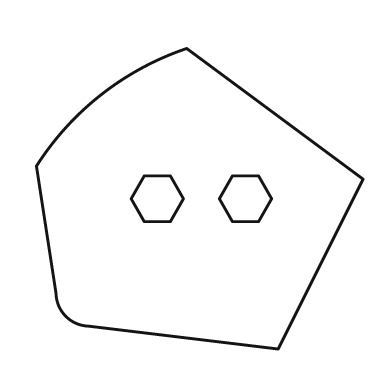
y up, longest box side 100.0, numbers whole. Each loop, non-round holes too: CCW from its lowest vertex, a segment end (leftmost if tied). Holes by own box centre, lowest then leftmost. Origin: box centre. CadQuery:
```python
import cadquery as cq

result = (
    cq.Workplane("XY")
    .moveTo(24.0, -46.0)
    .lineTo(50.0, 6.0)
    .lineTo(-4.0, 46.0)
    .threePointArc((-30.0, 32.0), (-50.0, 10.0))
    .lineTo(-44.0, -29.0)
    .threePointArc((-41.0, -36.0), (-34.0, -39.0))
    .close()
    .moveTo(-17.0, -7.0)
    .lineTo(-9.0, -7.0)
    .lineTo(-5.0, 0.0)
    .lineTo(-9.0, 7.0)
    .lineTo(-17.0, 7.0)
    .lineTo(-21.0, 0.0)
    .close()
    .moveTo(10.0, -7.0)
    .lineTo(18.0, -7.0)
    .lineTo(22.0, 0.0)
    .lineTo(18.0, 7.0)
    .lineTo(10.0, 7.0)
    .lineTo(6.0, 0.0)
    .close()
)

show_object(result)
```